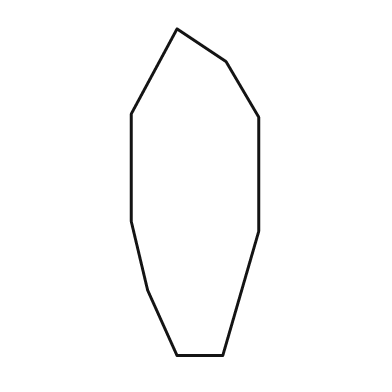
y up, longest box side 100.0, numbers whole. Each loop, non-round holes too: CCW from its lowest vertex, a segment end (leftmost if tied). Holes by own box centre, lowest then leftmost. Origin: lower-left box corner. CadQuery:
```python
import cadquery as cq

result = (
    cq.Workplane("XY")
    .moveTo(14.0, 0.0)
    .lineTo(28.0, 0.0)
    .lineTo(39.0, 38.0)
    .lineTo(39.0, 73.0)
    .lineTo(29.0, 90.0)
    .lineTo(14.0, 100.0)
    .lineTo(0.0, 74.0)
    .lineTo(0.0, 41.0)
    .lineTo(5.0, 20.0)
    .close()
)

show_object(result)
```